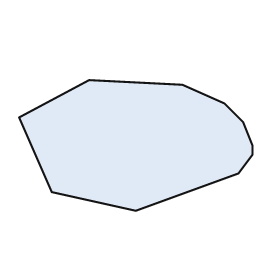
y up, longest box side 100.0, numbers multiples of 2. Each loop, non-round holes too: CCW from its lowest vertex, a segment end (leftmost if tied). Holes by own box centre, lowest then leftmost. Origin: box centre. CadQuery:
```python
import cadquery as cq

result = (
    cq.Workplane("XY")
    .moveTo(0.0, -28.0)
    .lineTo(44.0, -12.0)
    .lineTo(50.0, -4.0)
    .lineTo(50.0, 0.0)
    .lineTo(46.0, 10.0)
    .lineTo(38.0, 18.0)
    .lineTo(20.0, 26.0)
    .lineTo(-20.0, 28.0)
    .lineTo(-50.0, 12.0)
    .lineTo(-36.0, -20.0)
    .close()
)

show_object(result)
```